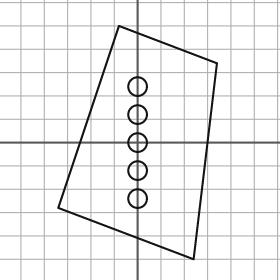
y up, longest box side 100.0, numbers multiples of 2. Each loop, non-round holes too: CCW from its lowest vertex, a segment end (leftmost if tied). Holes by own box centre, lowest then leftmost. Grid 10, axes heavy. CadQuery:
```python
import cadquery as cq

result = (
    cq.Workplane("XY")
    .moveTo(24.0, -50.0)
    .lineTo(34.0, 34.0)
    .lineTo(-8.0, 50.0)
    .lineTo(-34.0, -28.0)
    .close()
    .moveTo(0.0, -24.0)
    .circle(4.0)
    .moveTo(0.0, -12.0)
    .circle(4.0)
    .moveTo(0.0, 0.0)
    .circle(4.0)
    .moveTo(0.0, 12.0)
    .circle(4.0)
    .moveTo(0.0, 24.0)
    .circle(4.0)
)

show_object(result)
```